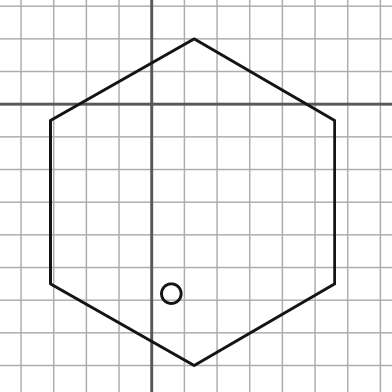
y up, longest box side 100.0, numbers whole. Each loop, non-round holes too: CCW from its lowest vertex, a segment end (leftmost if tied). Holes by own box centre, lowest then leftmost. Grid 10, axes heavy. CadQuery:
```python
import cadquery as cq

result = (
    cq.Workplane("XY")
    .moveTo(13.0, -80.0)
    .lineTo(56.0, -55.0)
    .lineTo(56.0, -5.0)
    .lineTo(13.0, 20.0)
    .lineTo(-31.0, -5.0)
    .lineTo(-31.0, -55.0)
    .close()
    .moveTo(6.0, -58.0)
    .circle(3.0)
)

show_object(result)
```